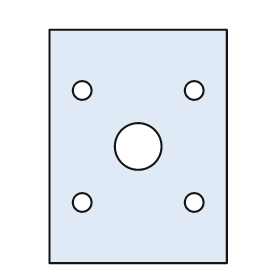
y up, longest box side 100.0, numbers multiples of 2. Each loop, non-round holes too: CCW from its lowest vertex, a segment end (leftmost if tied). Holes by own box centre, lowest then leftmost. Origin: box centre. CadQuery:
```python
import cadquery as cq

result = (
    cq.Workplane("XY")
    .moveTo(-38.0, -50.0)
    .lineTo(38.0, -50.0)
    .lineTo(38.0, 50.0)
    .lineTo(-38.0, 50.0)
    .close()
    .moveTo(-24.0, -24.0)
    .circle(4.0)
    .moveTo(24.0, -24.0)
    .circle(4.0)
    .moveTo(0.0, 0.0)
    .circle(10.0)
    .moveTo(-24.0, 24.0)
    .circle(4.0)
    .moveTo(24.0, 24.0)
    .circle(4.0)
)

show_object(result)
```